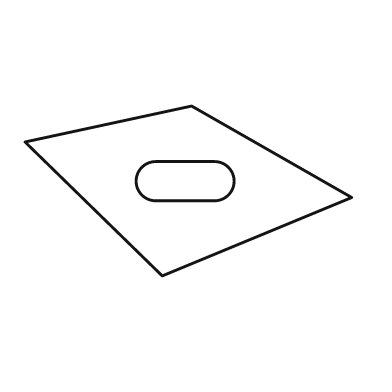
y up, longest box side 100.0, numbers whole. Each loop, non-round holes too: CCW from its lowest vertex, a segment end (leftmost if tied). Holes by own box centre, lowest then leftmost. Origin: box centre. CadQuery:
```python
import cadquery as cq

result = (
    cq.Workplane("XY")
    .moveTo(-8.0, -26.0)
    .lineTo(50.0, -2.0)
    .lineTo(1.0, 26.0)
    .lineTo(-50.0, 15.0)
    .close()
    .moveTo(-10.0, -3.0)
    .lineTo(8.0, -3.0)
    .threePointArc((14.0, 3.0), (8.0, 9.0))
    .lineTo(-10.0, 9.0)
    .threePointArc((-16.0, 3.0), (-10.0, -3.0))
    .close()
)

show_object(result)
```